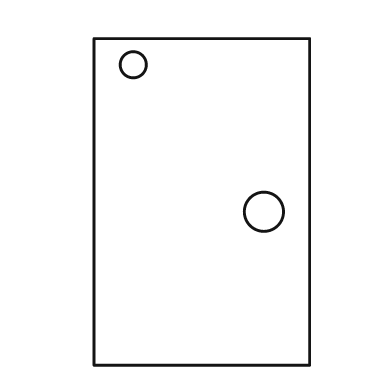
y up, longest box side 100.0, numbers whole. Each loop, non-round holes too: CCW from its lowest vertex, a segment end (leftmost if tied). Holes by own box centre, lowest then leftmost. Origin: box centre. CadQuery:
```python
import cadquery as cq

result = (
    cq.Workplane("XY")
    .moveTo(-33.0, -50.0)
    .lineTo(33.0, -50.0)
    .lineTo(33.0, 50.0)
    .lineTo(-33.0, 50.0)
    .close()
    .moveTo(19.0, -3.0)
    .circle(6.0)
    .moveTo(-21.0, 42.0)
    .circle(4.0)
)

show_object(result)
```